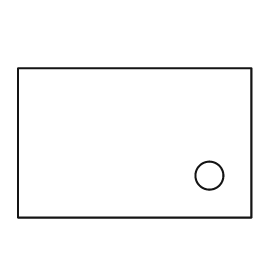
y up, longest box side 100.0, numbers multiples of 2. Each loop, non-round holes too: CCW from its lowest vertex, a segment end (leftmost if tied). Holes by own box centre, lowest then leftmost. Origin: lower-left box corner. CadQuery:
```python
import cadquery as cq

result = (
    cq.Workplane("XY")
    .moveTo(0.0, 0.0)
    .lineTo(100.0, 0.0)
    .lineTo(100.0, 64.0)
    .lineTo(0.0, 64.0)
    .close()
    .moveTo(82.0, 18.0)
    .circle(6.0)
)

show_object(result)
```